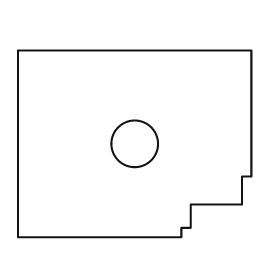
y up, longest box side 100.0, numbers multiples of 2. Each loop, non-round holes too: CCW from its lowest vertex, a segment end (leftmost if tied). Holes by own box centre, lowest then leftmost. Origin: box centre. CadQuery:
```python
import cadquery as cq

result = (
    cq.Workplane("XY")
    .moveTo(-50.0, -40.0)
    .lineTo(20.0, -40.0)
    .lineTo(20.0, -36.0)
    .lineTo(24.0, -36.0)
    .lineTo(24.0, -26.0)
    .lineTo(46.0, -26.0)
    .lineTo(46.0, -14.0)
    .lineTo(50.0, -14.0)
    .lineTo(50.0, 40.0)
    .lineTo(-50.0, 40.0)
    .close()
    .moveTo(0.0, 0.0)
    .circle(10.0)
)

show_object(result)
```